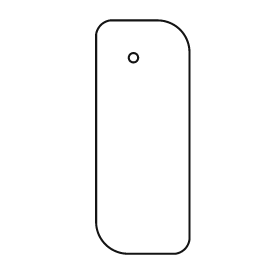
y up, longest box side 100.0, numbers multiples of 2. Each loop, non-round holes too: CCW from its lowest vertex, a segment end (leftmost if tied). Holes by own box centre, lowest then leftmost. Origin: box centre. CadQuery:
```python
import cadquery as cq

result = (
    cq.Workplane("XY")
    .moveTo(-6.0, -50.0)
    .lineTo(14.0, -50.0)
    .threePointArc((18.0, -48.0), (20.0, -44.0))
    .lineTo(20.0, 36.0)
    .threePointArc((16.0, 46.0), (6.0, 50.0))
    .lineTo(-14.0, 50.0)
    .threePointArc((-18.0, 48.0), (-20.0, 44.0))
    .lineTo(-20.0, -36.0)
    .threePointArc((-16.0, -46.0), (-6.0, -50.0))
    .close()
    .moveTo(-4.0, 34.0)
    .circle(2.0)
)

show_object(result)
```